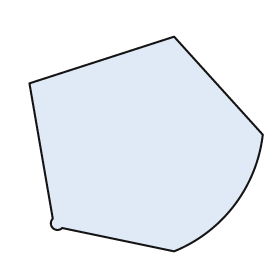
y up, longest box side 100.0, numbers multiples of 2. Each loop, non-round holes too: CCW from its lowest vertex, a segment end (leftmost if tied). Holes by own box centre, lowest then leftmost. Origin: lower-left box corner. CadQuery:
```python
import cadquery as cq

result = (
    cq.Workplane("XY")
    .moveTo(62.0, 0.0)
    .threePointArc((88.0, 20.0), (100.0, 50.0))
    .lineTo(62.0, 92.0)
    .lineTo(0.0, 72.0)
    .lineTo(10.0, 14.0)
    .threePointArc((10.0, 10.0), (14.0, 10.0))
    .close()
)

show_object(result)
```